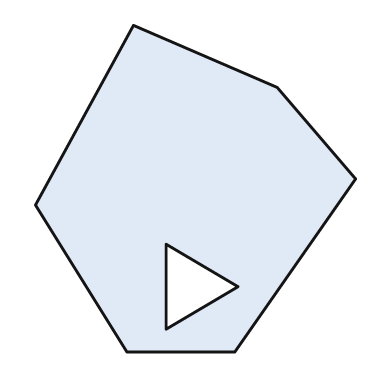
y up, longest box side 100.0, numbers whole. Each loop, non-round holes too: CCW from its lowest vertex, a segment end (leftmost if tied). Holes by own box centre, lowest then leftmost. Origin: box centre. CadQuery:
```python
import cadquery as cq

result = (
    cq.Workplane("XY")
    .moveTo(-21.0, -50.0)
    .lineTo(12.0, -50.0)
    .lineTo(49.0, 3.0)
    .lineTo(25.0, 31.0)
    .lineTo(-19.0, 50.0)
    .lineTo(-49.0, -5.0)
    .close()
    .moveTo(-9.0, -43.0)
    .lineTo(13.0, -30.0)
    .lineTo(-9.0, -17.0)
    .close()
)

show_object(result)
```